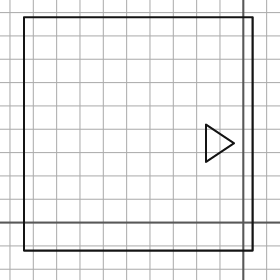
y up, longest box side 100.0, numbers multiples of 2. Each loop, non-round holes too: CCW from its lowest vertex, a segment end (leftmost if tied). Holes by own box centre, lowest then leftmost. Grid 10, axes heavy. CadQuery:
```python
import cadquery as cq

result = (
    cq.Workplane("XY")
    .moveTo(-94.0, -12.0)
    .lineTo(4.0, -12.0)
    .lineTo(4.0, 88.0)
    .lineTo(-94.0, 88.0)
    .close()
    .moveTo(-16.0, 26.0)
    .lineTo(-4.0, 34.0)
    .lineTo(-16.0, 42.0)
    .close()
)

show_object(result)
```